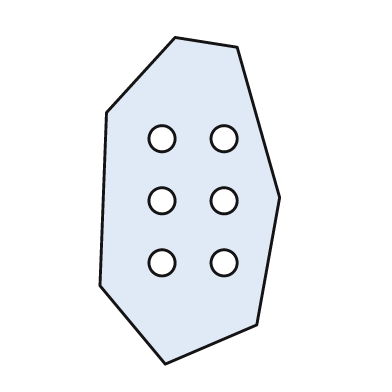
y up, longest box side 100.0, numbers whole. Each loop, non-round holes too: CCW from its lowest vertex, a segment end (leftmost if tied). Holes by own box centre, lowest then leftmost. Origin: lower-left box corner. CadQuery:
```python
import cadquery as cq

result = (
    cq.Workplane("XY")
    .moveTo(20.0, 0.0)
    .lineTo(48.0, 12.0)
    .lineTo(55.0, 51.0)
    .lineTo(42.0, 97.0)
    .lineTo(23.0, 100.0)
    .lineTo(2.0, 77.0)
    .lineTo(0.0, 24.0)
    .close()
    .moveTo(19.0, 31.0)
    .circle(4.0)
    .moveTo(38.0, 31.0)
    .circle(4.0)
    .moveTo(19.0, 50.0)
    .circle(4.0)
    .moveTo(38.0, 50.0)
    .circle(4.0)
    .moveTo(19.0, 69.0)
    .circle(4.0)
    .moveTo(38.0, 69.0)
    .circle(4.0)
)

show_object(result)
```